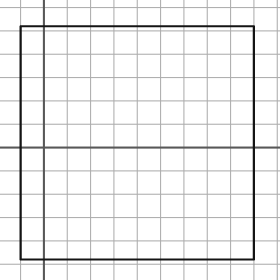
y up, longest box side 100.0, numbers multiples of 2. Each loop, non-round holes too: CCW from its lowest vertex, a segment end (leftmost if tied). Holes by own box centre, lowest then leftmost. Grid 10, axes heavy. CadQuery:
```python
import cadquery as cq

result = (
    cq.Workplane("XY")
    .moveTo(-10.0, -48.0)
    .lineTo(90.0, -48.0)
    .lineTo(90.0, 52.0)
    .lineTo(-10.0, 52.0)
    .close()
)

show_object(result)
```